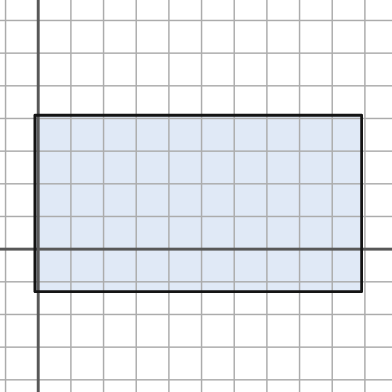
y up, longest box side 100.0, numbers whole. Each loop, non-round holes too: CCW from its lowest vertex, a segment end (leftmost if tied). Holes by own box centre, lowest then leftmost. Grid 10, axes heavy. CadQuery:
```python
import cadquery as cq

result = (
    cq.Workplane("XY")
    .moveTo(-1.0, -13.0)
    .lineTo(99.0, -13.0)
    .lineTo(99.0, 41.0)
    .lineTo(-1.0, 41.0)
    .close()
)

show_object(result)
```